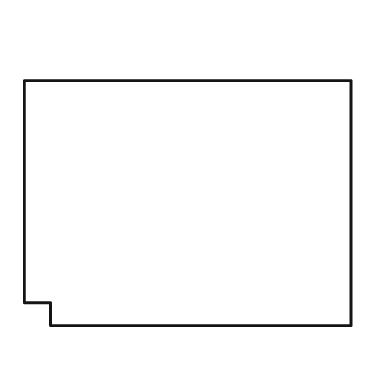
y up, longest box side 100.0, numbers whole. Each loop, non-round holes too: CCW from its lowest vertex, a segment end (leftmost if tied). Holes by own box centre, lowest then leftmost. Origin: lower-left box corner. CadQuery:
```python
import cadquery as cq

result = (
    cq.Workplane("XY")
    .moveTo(8.0, 0.0)
    .lineTo(100.0, 0.0)
    .lineTo(100.0, 75.0)
    .lineTo(0.0, 75.0)
    .lineTo(0.0, 7.0)
    .lineTo(8.0, 7.0)
    .close()
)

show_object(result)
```